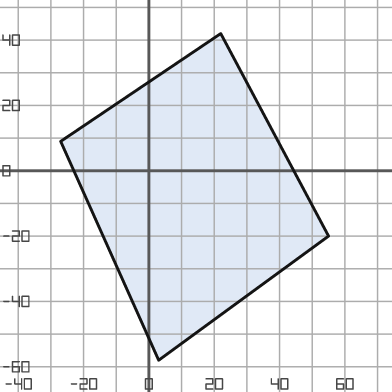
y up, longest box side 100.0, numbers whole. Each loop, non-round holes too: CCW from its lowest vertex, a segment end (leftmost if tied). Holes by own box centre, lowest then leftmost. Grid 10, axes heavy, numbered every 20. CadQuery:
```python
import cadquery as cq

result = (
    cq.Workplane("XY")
    .moveTo(3.0, -58.0)
    .lineTo(55.0, -20.0)
    .lineTo(22.0, 42.0)
    .lineTo(-27.0, 9.0)
    .close()
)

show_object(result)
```